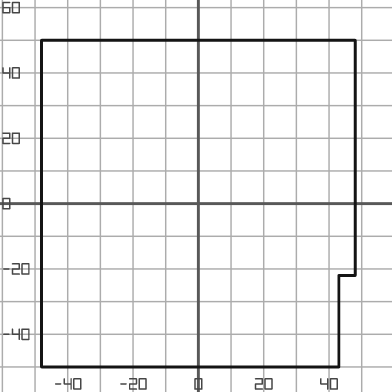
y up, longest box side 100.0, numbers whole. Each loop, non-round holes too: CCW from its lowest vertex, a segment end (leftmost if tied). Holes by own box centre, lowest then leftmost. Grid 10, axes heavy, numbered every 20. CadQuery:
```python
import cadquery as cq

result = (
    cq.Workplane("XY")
    .moveTo(-48.0, -50.0)
    .lineTo(43.0, -50.0)
    .lineTo(43.0, -22.0)
    .lineTo(48.0, -22.0)
    .lineTo(48.0, 50.0)
    .lineTo(-48.0, 50.0)
    .close()
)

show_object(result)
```